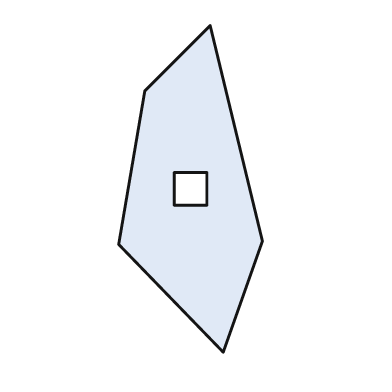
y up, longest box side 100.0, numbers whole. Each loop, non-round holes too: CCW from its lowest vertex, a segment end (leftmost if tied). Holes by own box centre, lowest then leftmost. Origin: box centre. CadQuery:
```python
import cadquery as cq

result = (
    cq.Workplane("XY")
    .moveTo(10.0, -50.0)
    .lineTo(22.0, -16.0)
    .lineTo(6.0, 50.0)
    .lineTo(-14.0, 30.0)
    .lineTo(-22.0, -17.0)
    .close()
    .moveTo(-5.0, -5.0)
    .lineTo(5.0, -5.0)
    .lineTo(5.0, 5.0)
    .lineTo(-5.0, 5.0)
    .close()
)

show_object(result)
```